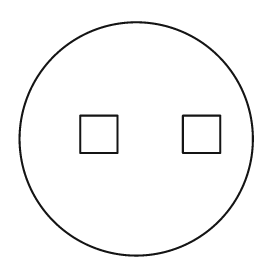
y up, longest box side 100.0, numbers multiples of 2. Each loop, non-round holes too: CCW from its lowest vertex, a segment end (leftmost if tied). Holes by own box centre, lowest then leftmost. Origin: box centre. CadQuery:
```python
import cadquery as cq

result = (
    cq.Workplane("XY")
    .moveTo(0.0, 0.0)
    .circle(50.0)
    .moveTo(-24.0, -6.0)
    .lineTo(-8.0, -6.0)
    .lineTo(-8.0, 10.0)
    .lineTo(-24.0, 10.0)
    .close()
    .moveTo(20.0, -6.0)
    .lineTo(36.0, -6.0)
    .lineTo(36.0, 10.0)
    .lineTo(20.0, 10.0)
    .close()
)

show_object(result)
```